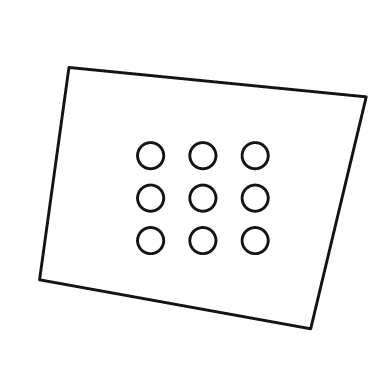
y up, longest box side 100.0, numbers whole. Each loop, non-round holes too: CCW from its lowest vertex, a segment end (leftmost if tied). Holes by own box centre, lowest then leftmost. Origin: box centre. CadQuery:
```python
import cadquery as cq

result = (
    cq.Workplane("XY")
    .moveTo(33.0, -40.0)
    .lineTo(50.0, 31.0)
    .lineTo(-41.0, 40.0)
    .lineTo(-50.0, -25.0)
    .close()
    .moveTo(-16.0, -13.0)
    .circle(4.0)
    .moveTo(0.0, -13.0)
    .circle(4.0)
    .moveTo(16.0, -13.0)
    .circle(4.0)
    .moveTo(-16.0, 0.0)
    .circle(4.0)
    .moveTo(0.0, 0.0)
    .circle(4.0)
    .moveTo(16.0, 0.0)
    .circle(4.0)
    .moveTo(-16.0, 13.0)
    .circle(4.0)
    .moveTo(0.0, 13.0)
    .circle(4.0)
    .moveTo(16.0, 13.0)
    .circle(4.0)
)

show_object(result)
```